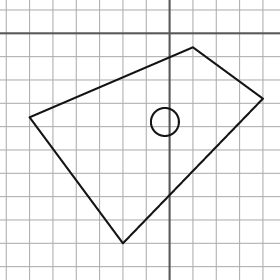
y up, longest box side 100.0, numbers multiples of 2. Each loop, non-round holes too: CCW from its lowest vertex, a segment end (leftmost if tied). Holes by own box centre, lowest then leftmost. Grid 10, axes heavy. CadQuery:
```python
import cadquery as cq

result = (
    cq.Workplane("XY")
    .moveTo(-20.0, -90.0)
    .lineTo(40.0, -28.0)
    .lineTo(10.0, -6.0)
    .lineTo(-60.0, -36.0)
    .close()
    .moveTo(-2.0, -38.0)
    .circle(6.0)
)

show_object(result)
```